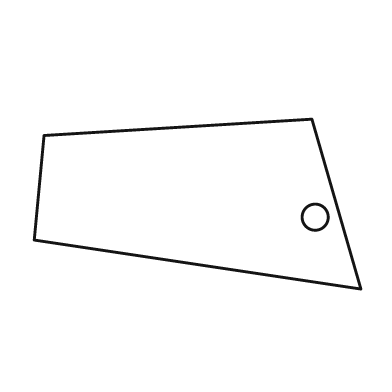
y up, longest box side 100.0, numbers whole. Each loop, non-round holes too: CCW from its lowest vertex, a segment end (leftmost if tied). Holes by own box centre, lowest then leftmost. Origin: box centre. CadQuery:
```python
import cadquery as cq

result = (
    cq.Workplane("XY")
    .moveTo(50.0, -26.0)
    .lineTo(35.0, 26.0)
    .lineTo(-47.0, 21.0)
    .lineTo(-50.0, -11.0)
    .close()
    .moveTo(36.0, -4.0)
    .circle(4.0)
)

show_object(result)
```